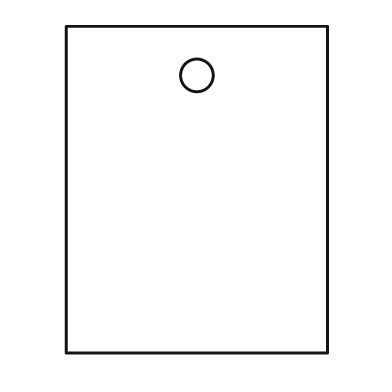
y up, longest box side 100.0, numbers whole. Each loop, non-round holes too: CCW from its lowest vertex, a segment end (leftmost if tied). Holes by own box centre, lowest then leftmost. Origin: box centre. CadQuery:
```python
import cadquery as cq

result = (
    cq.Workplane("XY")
    .moveTo(-40.0, -50.0)
    .lineTo(40.0, -50.0)
    .lineTo(40.0, 50.0)
    .lineTo(-40.0, 50.0)
    .close()
    .moveTo(0.0, 35.0)
    .circle(5.0)
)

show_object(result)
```